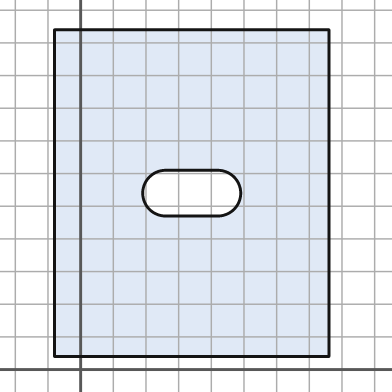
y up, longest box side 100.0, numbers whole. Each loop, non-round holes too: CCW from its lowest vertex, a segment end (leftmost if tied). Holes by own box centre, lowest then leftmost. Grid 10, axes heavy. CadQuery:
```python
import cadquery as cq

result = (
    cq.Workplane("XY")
    .moveTo(-8.0, 4.0)
    .lineTo(76.0, 4.0)
    .lineTo(76.0, 104.0)
    .lineTo(-8.0, 104.0)
    .close()
    .moveTo(26.0, 47.0)
    .lineTo(42.0, 47.0)
    .threePointArc((49.0, 54.0), (42.0, 61.0))
    .lineTo(26.0, 61.0)
    .threePointArc((19.0, 54.0), (26.0, 47.0))
    .close()
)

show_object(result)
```